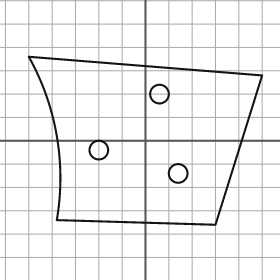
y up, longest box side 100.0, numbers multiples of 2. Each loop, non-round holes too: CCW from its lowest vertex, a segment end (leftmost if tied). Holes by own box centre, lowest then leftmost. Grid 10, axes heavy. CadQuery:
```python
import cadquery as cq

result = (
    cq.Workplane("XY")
    .moveTo(30.0, -36.0)
    .lineTo(50.0, 28.0)
    .lineTo(-50.0, 36.0)
    .threePointArc((-38.0, 2.0), (-38.0, -34.0))
    .close()
    .moveTo(14.0, -14.0)
    .circle(4.0)
    .moveTo(-20.0, -4.0)
    .circle(4.0)
    .moveTo(6.0, 20.0)
    .circle(4.0)
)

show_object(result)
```